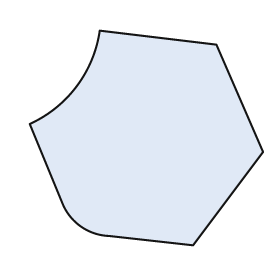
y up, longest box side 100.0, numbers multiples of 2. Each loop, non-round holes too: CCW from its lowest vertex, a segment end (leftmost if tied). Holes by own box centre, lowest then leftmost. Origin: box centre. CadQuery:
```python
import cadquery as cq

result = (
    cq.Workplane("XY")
    .moveTo(20.0, -46.0)
    .lineTo(50.0, -6.0)
    .lineTo(30.0, 40.0)
    .lineTo(-20.0, 46.0)
    .threePointArc((-30.0, 22.0), (-50.0, 6.0))
    .lineTo(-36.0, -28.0)
    .threePointArc((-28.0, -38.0), (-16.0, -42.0))
    .close()
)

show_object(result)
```